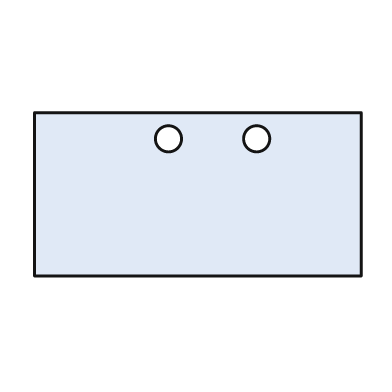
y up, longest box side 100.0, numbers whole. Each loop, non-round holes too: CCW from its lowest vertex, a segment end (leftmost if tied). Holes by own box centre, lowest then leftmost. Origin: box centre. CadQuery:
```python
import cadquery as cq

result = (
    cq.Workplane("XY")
    .moveTo(-50.0, -25.0)
    .lineTo(50.0, -25.0)
    .lineTo(50.0, 25.0)
    .lineTo(-50.0, 25.0)
    .close()
    .moveTo(-9.0, 17.0)
    .circle(4.0)
    .moveTo(18.0, 17.0)
    .circle(4.0)
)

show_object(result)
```